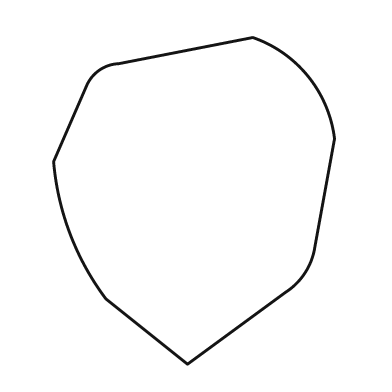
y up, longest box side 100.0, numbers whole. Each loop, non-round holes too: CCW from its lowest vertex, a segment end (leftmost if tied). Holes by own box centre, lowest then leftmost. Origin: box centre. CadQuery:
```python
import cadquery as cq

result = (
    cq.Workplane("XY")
    .moveTo(-2.0, -50.0)
    .lineTo(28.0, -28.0)
    .threePointArc((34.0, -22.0), (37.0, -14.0))
    .lineTo(43.0, 19.0)
    .threePointArc((35.0, 38.0), (18.0, 50.0))
    .lineTo(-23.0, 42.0)
    .threePointArc((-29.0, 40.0), (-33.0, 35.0))
    .lineTo(-43.0, 12.0)
    .threePointArc((-38.0, -10.0), (-27.0, -30.0))
    .close()
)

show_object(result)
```